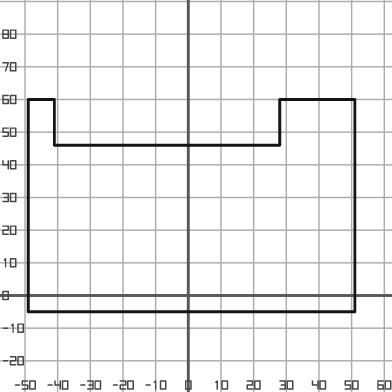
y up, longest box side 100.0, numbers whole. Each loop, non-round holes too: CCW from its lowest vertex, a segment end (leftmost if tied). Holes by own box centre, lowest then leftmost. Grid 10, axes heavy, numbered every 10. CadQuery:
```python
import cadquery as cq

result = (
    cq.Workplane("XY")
    .moveTo(-49.0, -5.0)
    .lineTo(51.0, -5.0)
    .lineTo(51.0, 60.0)
    .lineTo(28.0, 60.0)
    .lineTo(28.0, 46.0)
    .lineTo(-41.0, 46.0)
    .lineTo(-41.0, 60.0)
    .lineTo(-49.0, 60.0)
    .close()
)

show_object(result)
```